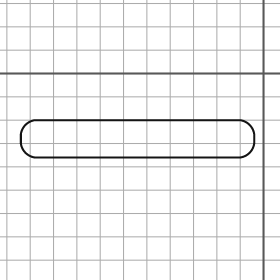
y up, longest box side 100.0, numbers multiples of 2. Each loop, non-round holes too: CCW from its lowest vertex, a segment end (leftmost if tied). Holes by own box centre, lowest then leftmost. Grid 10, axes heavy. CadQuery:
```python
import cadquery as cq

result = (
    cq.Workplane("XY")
    .moveTo(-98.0, -36.0)
    .lineTo(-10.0, -36.0)
    .threePointArc((-6.0, -34.0), (-4.0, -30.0))
    .lineTo(-4.0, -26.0)
    .threePointArc((-6.0, -22.0), (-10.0, -20.0))
    .lineTo(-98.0, -20.0)
    .threePointArc((-102.0, -22.0), (-104.0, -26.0))
    .lineTo(-104.0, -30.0)
    .threePointArc((-102.0, -34.0), (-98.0, -36.0))
    .close()
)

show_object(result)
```